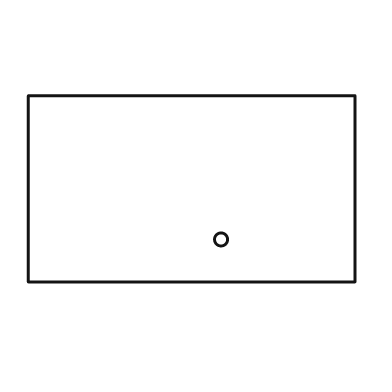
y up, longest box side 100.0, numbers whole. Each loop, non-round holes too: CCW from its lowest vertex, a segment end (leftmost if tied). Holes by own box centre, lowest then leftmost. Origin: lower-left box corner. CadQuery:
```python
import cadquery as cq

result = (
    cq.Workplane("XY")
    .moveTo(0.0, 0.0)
    .lineTo(100.0, 0.0)
    .lineTo(100.0, 57.0)
    .lineTo(0.0, 57.0)
    .close()
    .moveTo(59.0, 13.0)
    .circle(2.0)
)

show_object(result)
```